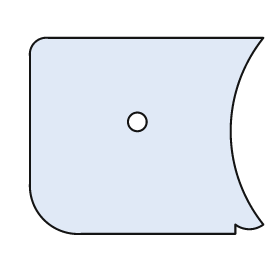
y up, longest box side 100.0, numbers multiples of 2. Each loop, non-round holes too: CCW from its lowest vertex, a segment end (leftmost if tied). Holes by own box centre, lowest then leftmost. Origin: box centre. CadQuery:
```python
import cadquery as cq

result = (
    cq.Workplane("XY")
    .moveTo(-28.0, -42.0)
    .lineTo(38.0, -42.0)
    .lineTo(38.0, -38.0)
    .threePointArc((44.0, -40.0), (50.0, -38.0))
    .threePointArc((36.0, 2.0), (50.0, 42.0))
    .lineTo(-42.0, 42.0)
    .threePointArc((-48.0, 40.0), (-50.0, 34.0))
    .lineTo(-50.0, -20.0)
    .threePointArc((-44.0, -36.0), (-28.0, -42.0))
    .close()
    .moveTo(-4.0, 6.0)
    .circle(4.0)
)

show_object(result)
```